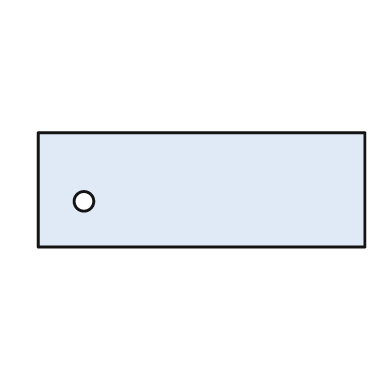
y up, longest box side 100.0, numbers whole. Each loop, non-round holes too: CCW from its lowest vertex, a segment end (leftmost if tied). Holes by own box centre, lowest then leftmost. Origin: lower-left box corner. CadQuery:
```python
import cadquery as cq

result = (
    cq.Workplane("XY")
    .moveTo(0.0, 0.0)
    .lineTo(100.0, 0.0)
    .lineTo(100.0, 35.0)
    .lineTo(0.0, 35.0)
    .close()
    .moveTo(14.0, 14.0)
    .circle(3.0)
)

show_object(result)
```